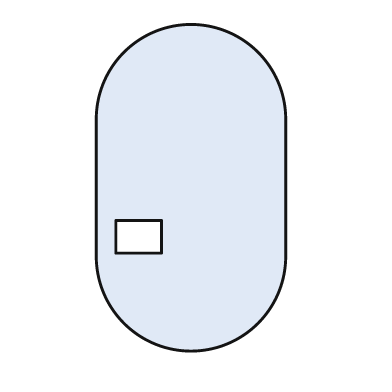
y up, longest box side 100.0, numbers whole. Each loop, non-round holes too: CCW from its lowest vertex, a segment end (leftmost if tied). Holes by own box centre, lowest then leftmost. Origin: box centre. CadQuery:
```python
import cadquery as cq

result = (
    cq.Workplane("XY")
    .moveTo(-29.0, -21.0)
    .threePointArc((0.0, -50.0), (29.0, -21.0))
    .lineTo(29.0, 21.0)
    .threePointArc((0.0, 50.0), (-29.0, 21.0))
    .close()
    .moveTo(-23.0, -20.0)
    .lineTo(-9.0, -20.0)
    .lineTo(-9.0, -10.0)
    .lineTo(-23.0, -10.0)
    .close()
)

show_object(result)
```